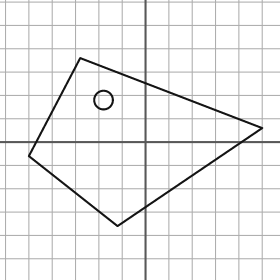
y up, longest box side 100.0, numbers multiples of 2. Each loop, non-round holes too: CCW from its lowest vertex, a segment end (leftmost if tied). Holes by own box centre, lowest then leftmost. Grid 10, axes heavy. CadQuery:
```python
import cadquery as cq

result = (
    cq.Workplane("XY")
    .moveTo(-12.0, -36.0)
    .lineTo(50.0, 6.0)
    .lineTo(-28.0, 36.0)
    .lineTo(-50.0, -6.0)
    .close()
    .moveTo(-18.0, 18.0)
    .circle(4.0)
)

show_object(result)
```